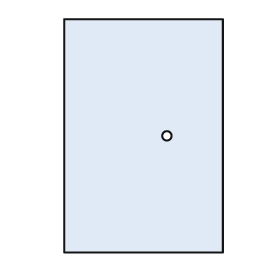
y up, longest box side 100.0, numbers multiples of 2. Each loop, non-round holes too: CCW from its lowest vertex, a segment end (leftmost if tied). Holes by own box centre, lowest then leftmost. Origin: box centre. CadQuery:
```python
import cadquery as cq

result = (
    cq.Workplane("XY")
    .moveTo(-34.0, -50.0)
    .lineTo(34.0, -50.0)
    .lineTo(34.0, 50.0)
    .lineTo(-34.0, 50.0)
    .close()
    .moveTo(10.0, 0.0)
    .circle(2.0)
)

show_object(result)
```